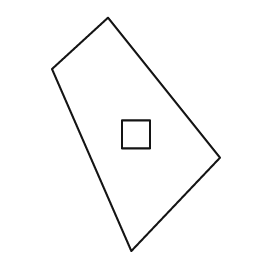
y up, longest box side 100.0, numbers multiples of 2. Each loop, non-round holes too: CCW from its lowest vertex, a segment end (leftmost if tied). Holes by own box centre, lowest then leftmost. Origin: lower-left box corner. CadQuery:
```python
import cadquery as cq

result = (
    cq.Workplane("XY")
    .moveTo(34.0, 0.0)
    .lineTo(72.0, 40.0)
    .lineTo(24.0, 100.0)
    .lineTo(0.0, 78.0)
    .close()
    .moveTo(30.0, 44.0)
    .lineTo(42.0, 44.0)
    .lineTo(42.0, 56.0)
    .lineTo(30.0, 56.0)
    .close()
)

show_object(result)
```